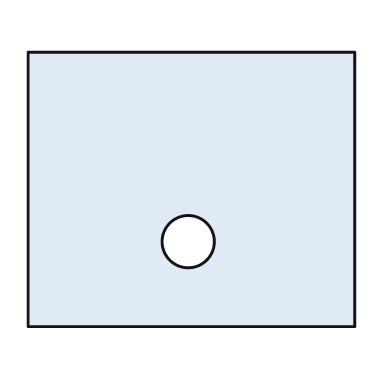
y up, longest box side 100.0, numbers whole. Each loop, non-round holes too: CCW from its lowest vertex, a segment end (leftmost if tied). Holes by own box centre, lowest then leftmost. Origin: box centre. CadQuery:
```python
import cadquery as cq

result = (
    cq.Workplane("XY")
    .moveTo(-50.0, -42.0)
    .lineTo(50.0, -42.0)
    .lineTo(50.0, 42.0)
    .lineTo(-50.0, 42.0)
    .close()
    .moveTo(-1.0, -16.0)
    .circle(8.0)
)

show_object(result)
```